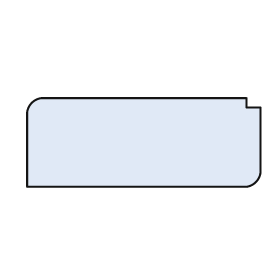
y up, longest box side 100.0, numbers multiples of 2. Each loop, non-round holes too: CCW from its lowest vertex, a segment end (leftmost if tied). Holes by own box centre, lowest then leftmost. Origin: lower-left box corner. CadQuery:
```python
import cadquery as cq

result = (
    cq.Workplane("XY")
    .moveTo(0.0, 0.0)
    .lineTo(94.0, 0.0)
    .threePointArc((98.0, 2.0), (100.0, 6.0))
    .lineTo(100.0, 34.0)
    .lineTo(94.0, 34.0)
    .lineTo(94.0, 38.0)
    .lineTo(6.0, 38.0)
    .threePointArc((2.0, 36.0), (0.0, 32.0))
    .close()
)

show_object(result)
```